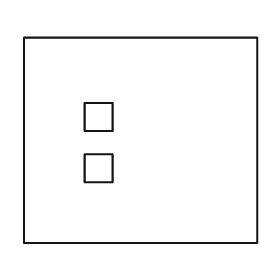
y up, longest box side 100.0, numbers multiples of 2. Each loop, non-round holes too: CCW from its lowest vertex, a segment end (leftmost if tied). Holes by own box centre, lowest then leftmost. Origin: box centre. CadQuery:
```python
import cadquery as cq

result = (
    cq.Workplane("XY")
    .moveTo(-50.0, -44.0)
    .lineTo(50.0, -44.0)
    .lineTo(50.0, 44.0)
    .lineTo(-50.0, 44.0)
    .close()
    .moveTo(-24.0, -18.0)
    .lineTo(-12.0, -18.0)
    .lineTo(-12.0, -6.0)
    .lineTo(-24.0, -6.0)
    .close()
    .moveTo(-24.0, 4.0)
    .lineTo(-12.0, 4.0)
    .lineTo(-12.0, 16.0)
    .lineTo(-24.0, 16.0)
    .close()
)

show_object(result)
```